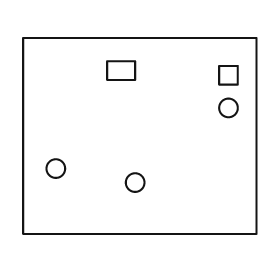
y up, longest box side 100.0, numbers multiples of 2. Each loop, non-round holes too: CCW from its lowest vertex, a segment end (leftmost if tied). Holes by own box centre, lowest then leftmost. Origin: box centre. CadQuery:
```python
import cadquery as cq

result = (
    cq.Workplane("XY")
    .moveTo(-50.0, -42.0)
    .lineTo(50.0, -42.0)
    .lineTo(50.0, 42.0)
    .lineTo(-50.0, 42.0)
    .close()
    .moveTo(-2.0, -20.0)
    .circle(4.0)
    .moveTo(-36.0, -14.0)
    .circle(4.0)
    .moveTo(38.0, 12.0)
    .circle(4.0)
    .moveTo(34.0, 22.0)
    .lineTo(42.0, 22.0)
    .lineTo(42.0, 30.0)
    .lineTo(34.0, 30.0)
    .close()
    .moveTo(-14.0, 24.0)
    .lineTo(-2.0, 24.0)
    .lineTo(-2.0, 32.0)
    .lineTo(-14.0, 32.0)
    .close()
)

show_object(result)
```